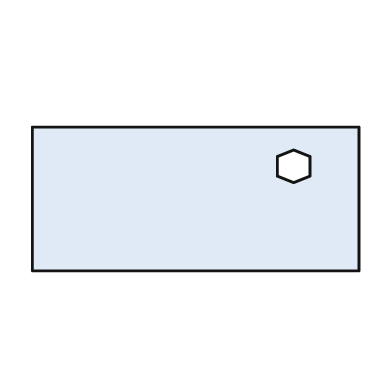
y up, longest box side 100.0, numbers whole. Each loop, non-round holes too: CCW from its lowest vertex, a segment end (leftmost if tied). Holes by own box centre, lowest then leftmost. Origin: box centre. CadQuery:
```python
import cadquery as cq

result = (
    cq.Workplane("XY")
    .moveTo(-50.0, -22.0)
    .lineTo(50.0, -22.0)
    .lineTo(50.0, 22.0)
    .lineTo(-50.0, 22.0)
    .close()
    .moveTo(30.0, 5.0)
    .lineTo(35.0, 7.0)
    .lineTo(35.0, 13.0)
    .lineTo(30.0, 15.0)
    .lineTo(25.0, 13.0)
    .lineTo(25.0, 7.0)
    .close()
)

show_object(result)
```